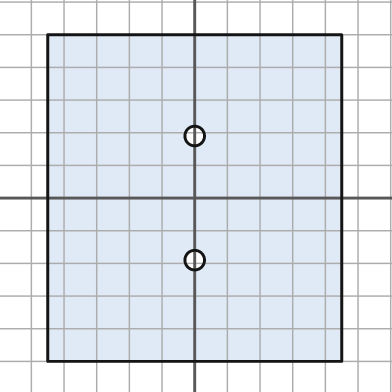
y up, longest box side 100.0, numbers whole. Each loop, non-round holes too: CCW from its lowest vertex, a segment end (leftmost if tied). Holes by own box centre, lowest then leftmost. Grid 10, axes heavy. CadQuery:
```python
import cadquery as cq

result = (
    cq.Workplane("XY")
    .moveTo(-45.0, -50.0)
    .lineTo(45.0, -50.0)
    .lineTo(45.0, 50.0)
    .lineTo(-45.0, 50.0)
    .close()
    .moveTo(0.0, -19.0)
    .circle(3.0)
    .moveTo(0.0, 19.0)
    .circle(3.0)
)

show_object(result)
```